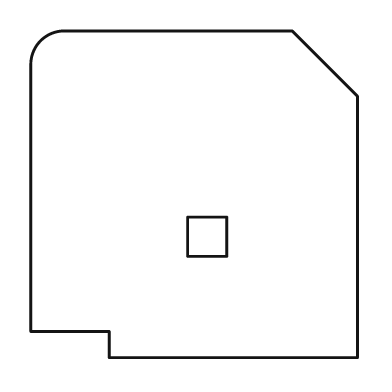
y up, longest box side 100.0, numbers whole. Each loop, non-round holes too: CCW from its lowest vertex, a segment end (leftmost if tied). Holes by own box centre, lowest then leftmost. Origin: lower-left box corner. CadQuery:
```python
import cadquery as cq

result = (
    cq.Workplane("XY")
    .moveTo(24.0, 0.0)
    .lineTo(100.0, 0.0)
    .lineTo(100.0, 80.0)
    .lineTo(80.0, 100.0)
    .lineTo(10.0, 100.0)
    .threePointArc((3.0, 97.0), (0.0, 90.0))
    .lineTo(0.0, 8.0)
    .lineTo(24.0, 8.0)
    .close()
    .moveTo(48.0, 31.0)
    .lineTo(60.0, 31.0)
    .lineTo(60.0, 43.0)
    .lineTo(48.0, 43.0)
    .close()
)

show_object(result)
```